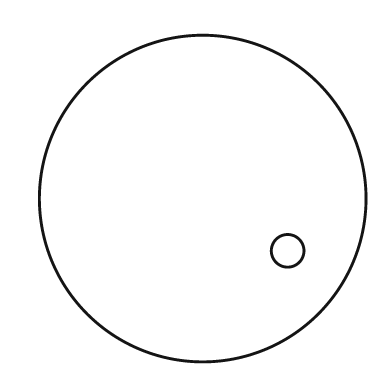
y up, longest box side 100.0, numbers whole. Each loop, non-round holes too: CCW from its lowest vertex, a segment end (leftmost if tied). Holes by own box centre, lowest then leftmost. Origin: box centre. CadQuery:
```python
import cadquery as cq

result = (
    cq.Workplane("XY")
    .moveTo(0.0, 0.0)
    .circle(50.0)
    .moveTo(26.0, -16.0)
    .circle(5.0)
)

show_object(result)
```